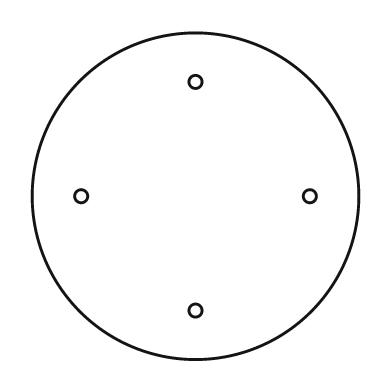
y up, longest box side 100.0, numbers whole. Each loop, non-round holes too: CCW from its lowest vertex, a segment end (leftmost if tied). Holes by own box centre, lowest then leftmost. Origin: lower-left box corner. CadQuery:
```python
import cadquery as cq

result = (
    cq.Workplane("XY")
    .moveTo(50.0, 50.0)
    .circle(50.0)
    .moveTo(50.0, 15.0)
    .circle(2.0)
    .moveTo(15.0, 50.0)
    .circle(2.0)
    .moveTo(85.0, 50.0)
    .circle(2.0)
    .moveTo(50.0, 85.0)
    .circle(2.0)
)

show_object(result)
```